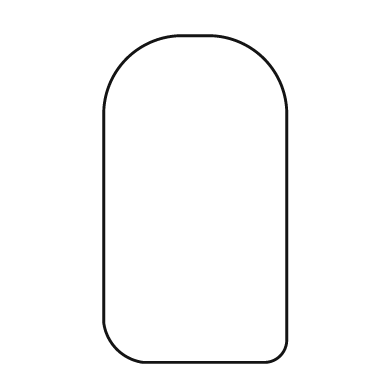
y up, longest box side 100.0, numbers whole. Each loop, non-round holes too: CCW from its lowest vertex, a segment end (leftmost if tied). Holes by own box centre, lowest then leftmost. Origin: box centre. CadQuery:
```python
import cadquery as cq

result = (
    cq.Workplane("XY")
    .moveTo(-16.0, -50.0)
    .lineTo(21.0, -50.0)
    .threePointArc((26.0, -48.0), (28.0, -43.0))
    .lineTo(28.0, 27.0)
    .threePointArc((21.0, 43.0), (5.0, 50.0))
    .lineTo(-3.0, 50.0)
    .threePointArc((-21.0, 43.0), (-28.0, 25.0))
    .lineTo(-28.0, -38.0)
    .threePointArc((-24.0, -46.0), (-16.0, -50.0))
    .close()
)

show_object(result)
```